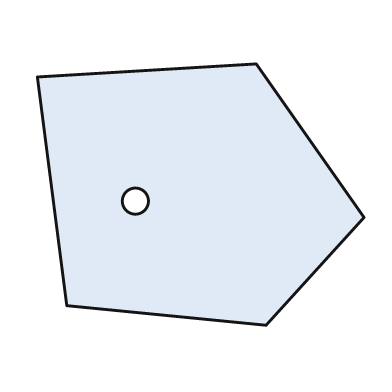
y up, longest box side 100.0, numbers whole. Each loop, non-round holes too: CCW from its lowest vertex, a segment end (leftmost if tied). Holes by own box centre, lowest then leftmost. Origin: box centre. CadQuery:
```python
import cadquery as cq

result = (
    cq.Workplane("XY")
    .moveTo(20.0, -40.0)
    .lineTo(50.0, -7.0)
    .lineTo(17.0, 40.0)
    .lineTo(-50.0, 36.0)
    .lineTo(-41.0, -34.0)
    .close()
    .moveTo(-20.0, -2.0)
    .circle(4.0)
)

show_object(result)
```